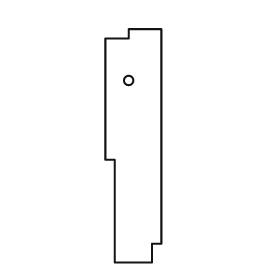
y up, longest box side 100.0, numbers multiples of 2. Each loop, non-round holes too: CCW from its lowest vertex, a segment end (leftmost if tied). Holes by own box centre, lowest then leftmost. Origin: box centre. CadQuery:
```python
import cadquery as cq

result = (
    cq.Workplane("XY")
    .moveTo(-8.0, -50.0)
    .lineTo(8.0, -50.0)
    .lineTo(8.0, -42.0)
    .lineTo(12.0, -42.0)
    .lineTo(12.0, 50.0)
    .lineTo(-2.0, 50.0)
    .lineTo(-2.0, 46.0)
    .lineTo(-12.0, 46.0)
    .lineTo(-12.0, -6.0)
    .lineTo(-8.0, -6.0)
    .close()
    .moveTo(-2.0, 28.0)
    .circle(2.0)
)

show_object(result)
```